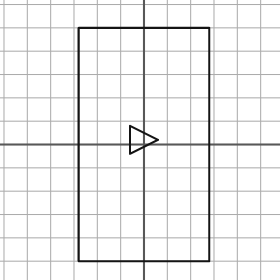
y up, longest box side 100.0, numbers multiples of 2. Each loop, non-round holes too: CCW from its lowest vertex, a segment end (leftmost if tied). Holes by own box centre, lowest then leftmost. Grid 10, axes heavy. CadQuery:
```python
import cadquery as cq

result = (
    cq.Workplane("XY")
    .moveTo(-28.0, -50.0)
    .lineTo(28.0, -50.0)
    .lineTo(28.0, 50.0)
    .lineTo(-28.0, 50.0)
    .close()
    .moveTo(-6.0, -4.0)
    .lineTo(6.0, 2.0)
    .lineTo(-6.0, 8.0)
    .close()
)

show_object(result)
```